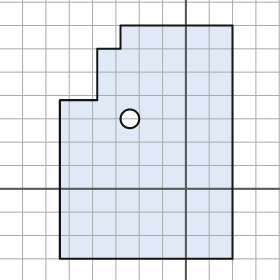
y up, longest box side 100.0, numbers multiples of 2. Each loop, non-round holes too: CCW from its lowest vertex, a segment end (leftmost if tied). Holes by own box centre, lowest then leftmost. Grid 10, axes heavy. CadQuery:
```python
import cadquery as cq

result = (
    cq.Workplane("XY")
    .moveTo(-54.0, -30.0)
    .lineTo(20.0, -30.0)
    .lineTo(20.0, 70.0)
    .lineTo(-28.0, 70.0)
    .lineTo(-28.0, 60.0)
    .lineTo(-38.0, 60.0)
    .lineTo(-38.0, 38.0)
    .lineTo(-54.0, 38.0)
    .close()
    .moveTo(-24.0, 30.0)
    .circle(4.0)
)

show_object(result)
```